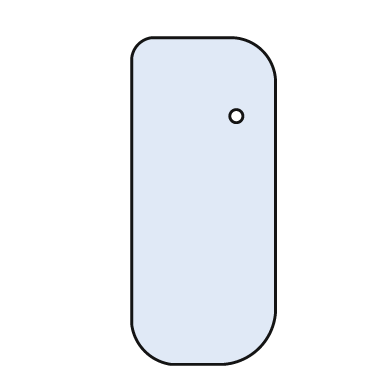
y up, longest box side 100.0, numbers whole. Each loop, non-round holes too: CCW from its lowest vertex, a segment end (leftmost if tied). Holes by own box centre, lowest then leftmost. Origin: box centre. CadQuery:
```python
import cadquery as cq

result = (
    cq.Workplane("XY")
    .moveTo(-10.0, -50.0)
    .lineTo(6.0, -50.0)
    .threePointArc((17.0, -45.0), (22.0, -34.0))
    .lineTo(22.0, 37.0)
    .threePointArc((18.0, 46.0), (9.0, 50.0))
    .lineTo(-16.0, 50.0)
    .threePointArc((-20.0, 48.0), (-22.0, 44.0))
    .lineTo(-22.0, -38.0)
    .threePointArc((-18.0, -46.0), (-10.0, -50.0))
    .close()
    .moveTo(10.0, 26.0)
    .circle(2.0)
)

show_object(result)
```